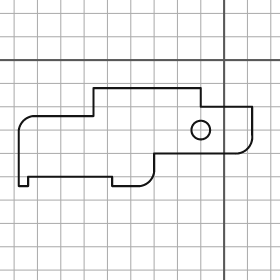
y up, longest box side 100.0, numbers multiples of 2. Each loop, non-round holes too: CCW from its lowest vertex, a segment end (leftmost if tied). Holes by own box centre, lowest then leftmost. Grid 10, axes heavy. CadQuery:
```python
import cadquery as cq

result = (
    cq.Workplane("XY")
    .moveTo(-88.0, -54.0)
    .lineTo(-84.0, -54.0)
    .lineTo(-84.0, -50.0)
    .lineTo(-48.0, -50.0)
    .lineTo(-48.0, -54.0)
    .lineTo(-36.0, -54.0)
    .threePointArc((-32.0, -52.0), (-30.0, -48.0))
    .lineTo(-30.0, -40.0)
    .lineTo(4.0, -40.0)
    .threePointArc((10.0, -38.0), (12.0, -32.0))
    .lineTo(12.0, -20.0)
    .lineTo(-10.0, -20.0)
    .lineTo(-10.0, -12.0)
    .lineTo(-56.0, -12.0)
    .lineTo(-56.0, -24.0)
    .lineTo(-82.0, -24.0)
    .threePointArc((-86.0, -26.0), (-88.0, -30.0))
    .close()
    .moveTo(-10.0, -30.0)
    .circle(4.0)
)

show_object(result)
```